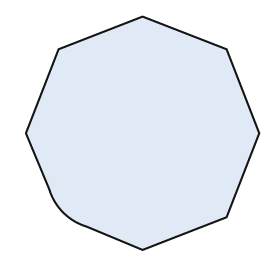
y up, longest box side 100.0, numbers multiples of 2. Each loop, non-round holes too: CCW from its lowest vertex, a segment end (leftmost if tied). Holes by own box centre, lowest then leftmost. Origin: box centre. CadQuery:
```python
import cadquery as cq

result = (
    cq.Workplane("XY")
    .moveTo(0.0, -50.0)
    .lineTo(36.0, -36.0)
    .lineTo(50.0, 0.0)
    .lineTo(36.0, 36.0)
    .lineTo(0.0, 50.0)
    .lineTo(-36.0, 36.0)
    .lineTo(-50.0, 0.0)
    .lineTo(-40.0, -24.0)
    .threePointArc((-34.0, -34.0), (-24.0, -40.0))
    .close()
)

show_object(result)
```